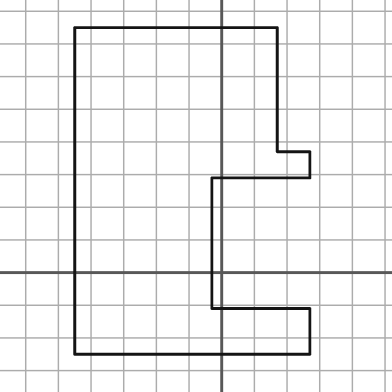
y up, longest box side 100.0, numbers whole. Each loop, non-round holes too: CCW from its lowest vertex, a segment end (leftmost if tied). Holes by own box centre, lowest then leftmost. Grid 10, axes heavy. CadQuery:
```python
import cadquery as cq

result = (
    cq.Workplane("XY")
    .moveTo(-45.0, -25.0)
    .lineTo(27.0, -25.0)
    .lineTo(27.0, -11.0)
    .lineTo(-3.0, -11.0)
    .lineTo(-3.0, 29.0)
    .lineTo(27.0, 29.0)
    .lineTo(27.0, 37.0)
    .lineTo(17.0, 37.0)
    .lineTo(17.0, 75.0)
    .lineTo(-45.0, 75.0)
    .close()
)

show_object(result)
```